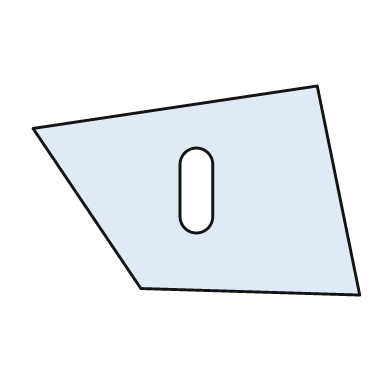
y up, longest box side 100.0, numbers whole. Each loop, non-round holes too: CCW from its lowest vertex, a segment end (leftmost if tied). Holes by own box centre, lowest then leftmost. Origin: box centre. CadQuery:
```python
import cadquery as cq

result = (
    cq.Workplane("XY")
    .moveTo(50.0, -32.0)
    .lineTo(37.0, 32.0)
    .lineTo(-50.0, 19.0)
    .lineTo(-17.0, -30.0)
    .close()
    .moveTo(-5.0, -8.0)
    .threePointArc((0.0, -13.0), (5.0, -8.0))
    .lineTo(5.0, 8.0)
    .threePointArc((0.0, 13.0), (-5.0, 8.0))
    .close()
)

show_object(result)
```